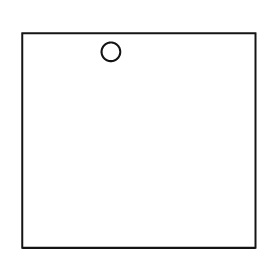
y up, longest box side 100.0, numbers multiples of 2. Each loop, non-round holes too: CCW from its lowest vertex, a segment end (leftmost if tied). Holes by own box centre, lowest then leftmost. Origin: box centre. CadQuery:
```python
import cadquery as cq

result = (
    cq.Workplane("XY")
    .moveTo(-50.0, -46.0)
    .lineTo(50.0, -46.0)
    .lineTo(50.0, 46.0)
    .lineTo(-50.0, 46.0)
    .close()
    .moveTo(-12.0, 38.0)
    .circle(4.0)
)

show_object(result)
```